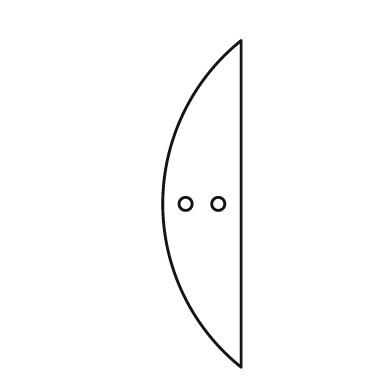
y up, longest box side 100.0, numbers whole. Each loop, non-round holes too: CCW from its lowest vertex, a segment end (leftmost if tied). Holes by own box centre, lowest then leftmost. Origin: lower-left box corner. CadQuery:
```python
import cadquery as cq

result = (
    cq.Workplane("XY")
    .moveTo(24.0, 0.0)
    .lineTo(24.0, 100.0)
    .threePointArc((0.0, 50.0), (24.0, 0.0))
    .close()
    .moveTo(7.0, 50.0)
    .circle(2.0)
    .moveTo(17.0, 50.0)
    .circle(2.0)
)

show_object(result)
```